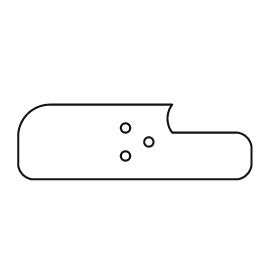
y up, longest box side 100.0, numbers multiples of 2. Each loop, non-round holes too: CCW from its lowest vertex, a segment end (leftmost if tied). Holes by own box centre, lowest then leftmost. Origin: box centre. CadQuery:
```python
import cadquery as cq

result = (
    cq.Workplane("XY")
    .moveTo(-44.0, -16.0)
    .lineTo(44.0, -16.0)
    .threePointArc((48.0, -14.0), (50.0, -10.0))
    .lineTo(50.0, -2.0)
    .threePointArc((48.0, 2.0), (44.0, 4.0))
    .lineTo(16.0, 4.0)
    .threePointArc((14.0, 10.0), (16.0, 16.0))
    .lineTo(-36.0, 16.0)
    .threePointArc((-46.0, 12.0), (-50.0, 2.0))
    .lineTo(-50.0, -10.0)
    .threePointArc((-48.0, -14.0), (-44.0, -16.0))
    .close()
    .moveTo(-4.0, -6.0)
    .circle(2.0)
    .moveTo(6.0, 0.0)
    .circle(2.0)
    .moveTo(-4.0, 6.0)
    .circle(2.0)
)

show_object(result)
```